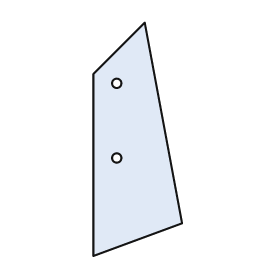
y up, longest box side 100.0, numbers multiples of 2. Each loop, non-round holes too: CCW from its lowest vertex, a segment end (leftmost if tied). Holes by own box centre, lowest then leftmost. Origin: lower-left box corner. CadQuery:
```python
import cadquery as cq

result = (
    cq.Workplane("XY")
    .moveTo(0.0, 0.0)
    .lineTo(38.0, 14.0)
    .lineTo(22.0, 100.0)
    .lineTo(0.0, 78.0)
    .close()
    .moveTo(10.0, 42.0)
    .circle(2.0)
    .moveTo(10.0, 74.0)
    .circle(2.0)
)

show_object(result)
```